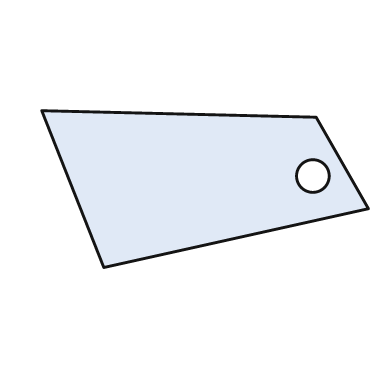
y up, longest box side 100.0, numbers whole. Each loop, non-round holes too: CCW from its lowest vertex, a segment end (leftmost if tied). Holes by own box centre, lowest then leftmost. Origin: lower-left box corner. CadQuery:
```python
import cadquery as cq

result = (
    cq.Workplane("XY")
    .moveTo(19.0, 0.0)
    .lineTo(100.0, 18.0)
    .lineTo(84.0, 46.0)
    .lineTo(0.0, 48.0)
    .close()
    .moveTo(83.0, 28.0)
    .circle(5.0)
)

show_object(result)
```